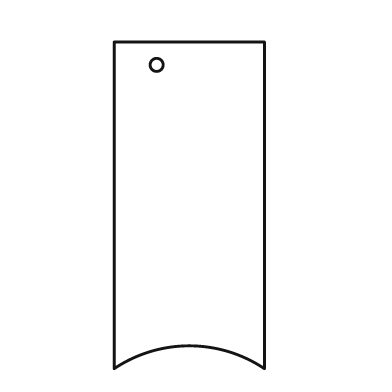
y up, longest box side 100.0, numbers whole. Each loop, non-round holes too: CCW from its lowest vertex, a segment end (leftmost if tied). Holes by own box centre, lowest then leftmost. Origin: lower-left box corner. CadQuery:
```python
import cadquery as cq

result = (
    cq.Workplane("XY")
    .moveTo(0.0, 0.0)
    .threePointArc((23.0, 7.0), (46.0, 0.0))
    .lineTo(46.0, 100.0)
    .lineTo(0.0, 100.0)
    .close()
    .moveTo(13.0, 93.0)
    .circle(2.0)
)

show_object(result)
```